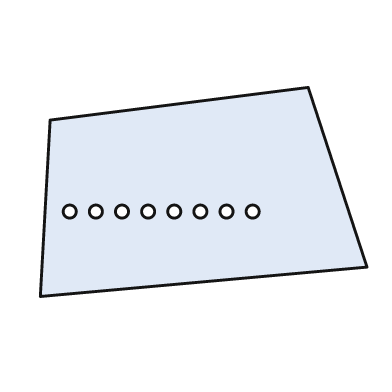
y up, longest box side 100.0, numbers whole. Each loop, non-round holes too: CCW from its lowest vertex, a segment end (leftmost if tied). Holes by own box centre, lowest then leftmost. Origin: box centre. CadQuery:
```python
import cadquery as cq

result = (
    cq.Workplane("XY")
    .moveTo(-50.0, -32.0)
    .lineTo(50.0, -23.0)
    .lineTo(32.0, 32.0)
    .lineTo(-47.0, 22.0)
    .close()
    .moveTo(-41.0, -6.0)
    .circle(2.0)
    .moveTo(-33.0, -6.0)
    .circle(2.0)
    .moveTo(-25.0, -6.0)
    .circle(2.0)
    .moveTo(-17.0, -6.0)
    .circle(2.0)
    .moveTo(-9.0, -6.0)
    .circle(2.0)
    .moveTo(-1.0, -6.0)
    .circle(2.0)
    .moveTo(7.0, -6.0)
    .circle(2.0)
    .moveTo(15.0, -6.0)
    .circle(2.0)
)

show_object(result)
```